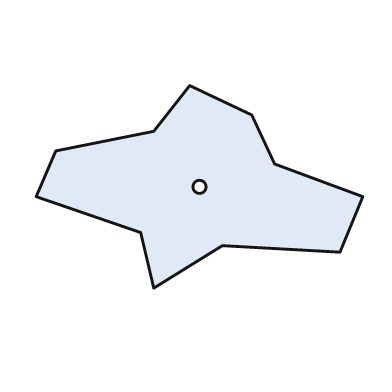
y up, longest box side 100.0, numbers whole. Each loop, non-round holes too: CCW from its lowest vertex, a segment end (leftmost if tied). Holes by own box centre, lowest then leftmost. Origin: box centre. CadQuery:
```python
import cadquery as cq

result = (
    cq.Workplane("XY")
    .moveTo(-14.0, -31.0)
    .lineTo(7.0, -18.0)
    .lineTo(43.0, -20.0)
    .lineTo(50.0, -3.0)
    .lineTo(23.0, 7.0)
    .lineTo(16.0, 22.0)
    .lineTo(-3.0, 31.0)
    .lineTo(-14.0, 17.0)
    .lineTo(-44.0, 11.0)
    .lineTo(-50.0, -3.0)
    .lineTo(-18.0, -14.0)
    .close()
    .moveTo(0.0, 0.0)
    .circle(2.0)
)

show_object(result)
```